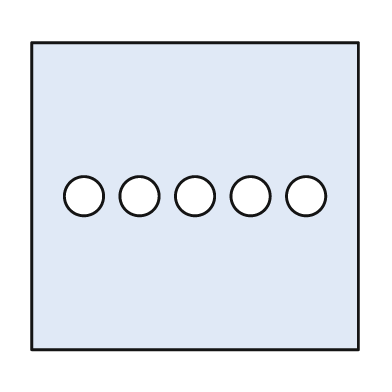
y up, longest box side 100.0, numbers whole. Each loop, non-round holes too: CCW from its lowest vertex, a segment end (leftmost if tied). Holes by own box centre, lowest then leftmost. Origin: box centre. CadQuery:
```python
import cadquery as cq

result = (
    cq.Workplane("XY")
    .moveTo(-50.0, -47.0)
    .lineTo(50.0, -47.0)
    .lineTo(50.0, 47.0)
    .lineTo(-50.0, 47.0)
    .close()
    .moveTo(-34.0, 0.0)
    .circle(6.0)
    .moveTo(-17.0, 0.0)
    .circle(6.0)
    .moveTo(0.0, 0.0)
    .circle(6.0)
    .moveTo(17.0, 0.0)
    .circle(6.0)
    .moveTo(34.0, 0.0)
    .circle(6.0)
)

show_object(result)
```